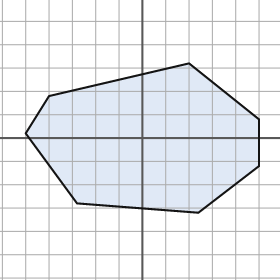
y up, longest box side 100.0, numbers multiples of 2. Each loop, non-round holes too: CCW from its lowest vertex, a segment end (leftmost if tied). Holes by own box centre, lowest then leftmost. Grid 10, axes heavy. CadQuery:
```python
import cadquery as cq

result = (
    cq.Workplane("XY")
    .moveTo(24.0, -32.0)
    .lineTo(50.0, -12.0)
    .lineTo(50.0, 8.0)
    .lineTo(20.0, 32.0)
    .lineTo(-40.0, 18.0)
    .lineTo(-50.0, 2.0)
    .lineTo(-28.0, -28.0)
    .close()
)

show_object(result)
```